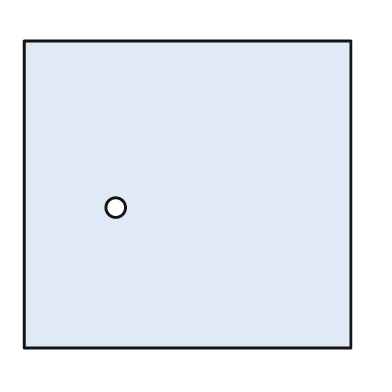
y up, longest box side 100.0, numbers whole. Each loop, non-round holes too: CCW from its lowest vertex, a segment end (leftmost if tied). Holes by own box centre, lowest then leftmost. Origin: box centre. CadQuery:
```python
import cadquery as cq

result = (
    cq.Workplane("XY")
    .moveTo(-50.0, -47.0)
    .lineTo(50.0, -47.0)
    .lineTo(50.0, 47.0)
    .lineTo(-50.0, 47.0)
    .close()
    .moveTo(-22.0, -4.0)
    .circle(3.0)
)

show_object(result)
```